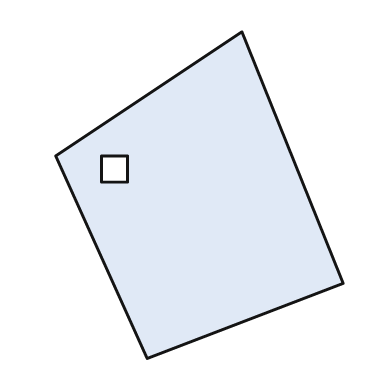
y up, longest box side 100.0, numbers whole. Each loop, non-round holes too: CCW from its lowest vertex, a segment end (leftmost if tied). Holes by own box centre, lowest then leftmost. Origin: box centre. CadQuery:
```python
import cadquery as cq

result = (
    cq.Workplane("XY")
    .moveTo(-16.0, -50.0)
    .lineTo(44.0, -27.0)
    .lineTo(13.0, 50.0)
    .lineTo(-44.0, 12.0)
    .close()
    .moveTo(-30.0, 4.0)
    .lineTo(-22.0, 4.0)
    .lineTo(-22.0, 12.0)
    .lineTo(-30.0, 12.0)
    .close()
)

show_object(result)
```